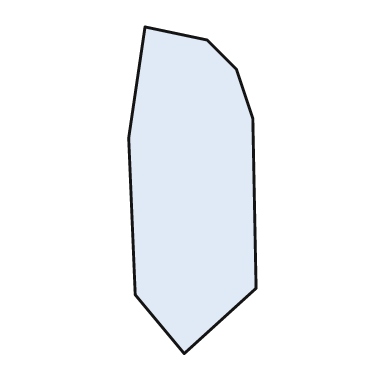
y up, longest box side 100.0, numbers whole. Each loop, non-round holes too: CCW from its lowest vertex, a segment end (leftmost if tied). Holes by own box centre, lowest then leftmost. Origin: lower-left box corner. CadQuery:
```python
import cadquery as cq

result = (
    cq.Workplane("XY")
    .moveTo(17.0, 0.0)
    .lineTo(39.0, 20.0)
    .lineTo(38.0, 72.0)
    .lineTo(33.0, 87.0)
    .lineTo(24.0, 96.0)
    .lineTo(5.0, 100.0)
    .lineTo(0.0, 66.0)
    .lineTo(2.0, 18.0)
    .close()
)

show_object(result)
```